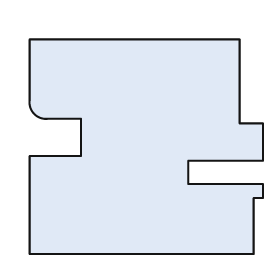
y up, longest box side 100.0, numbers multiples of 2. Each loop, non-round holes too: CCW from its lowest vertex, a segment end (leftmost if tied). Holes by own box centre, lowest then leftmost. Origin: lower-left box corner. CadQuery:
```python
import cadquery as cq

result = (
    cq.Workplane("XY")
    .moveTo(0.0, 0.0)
    .lineTo(96.0, 0.0)
    .lineTo(96.0, 24.0)
    .lineTo(100.0, 24.0)
    .lineTo(100.0, 30.0)
    .lineTo(68.0, 30.0)
    .lineTo(68.0, 40.0)
    .lineTo(100.0, 40.0)
    .lineTo(100.0, 56.0)
    .lineTo(90.0, 56.0)
    .lineTo(90.0, 92.0)
    .lineTo(0.0, 92.0)
    .lineTo(0.0, 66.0)
    .threePointArc((2.0, 60.0), (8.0, 58.0))
    .lineTo(22.0, 58.0)
    .lineTo(22.0, 42.0)
    .lineTo(0.0, 42.0)
    .close()
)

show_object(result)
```